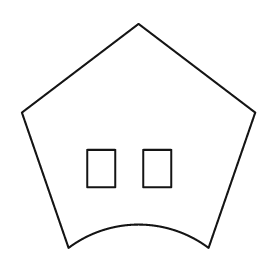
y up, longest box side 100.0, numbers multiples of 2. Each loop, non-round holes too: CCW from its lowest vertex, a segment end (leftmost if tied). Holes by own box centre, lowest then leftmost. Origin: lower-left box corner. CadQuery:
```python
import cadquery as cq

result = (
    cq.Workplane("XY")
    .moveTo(20.0, 0.0)
    .threePointArc((50.0, 10.0), (80.0, 0.0))
    .lineTo(100.0, 58.0)
    .lineTo(50.0, 96.0)
    .lineTo(0.0, 58.0)
    .close()
    .moveTo(28.0, 26.0)
    .lineTo(40.0, 26.0)
    .lineTo(40.0, 42.0)
    .lineTo(28.0, 42.0)
    .close()
    .moveTo(52.0, 26.0)
    .lineTo(64.0, 26.0)
    .lineTo(64.0, 42.0)
    .lineTo(52.0, 42.0)
    .close()
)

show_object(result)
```